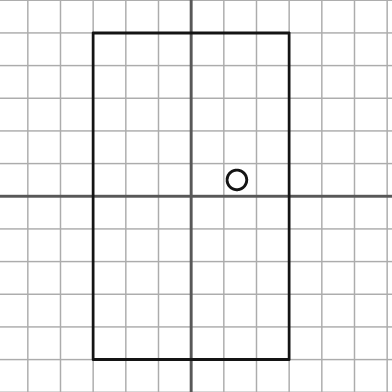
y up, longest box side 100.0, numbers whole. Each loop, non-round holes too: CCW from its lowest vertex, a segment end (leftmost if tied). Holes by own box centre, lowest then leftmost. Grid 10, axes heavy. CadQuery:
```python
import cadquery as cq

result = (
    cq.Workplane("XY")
    .moveTo(-30.0, -50.0)
    .lineTo(30.0, -50.0)
    .lineTo(30.0, 50.0)
    .lineTo(-30.0, 50.0)
    .close()
    .moveTo(14.0, 5.0)
    .circle(3.0)
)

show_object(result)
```